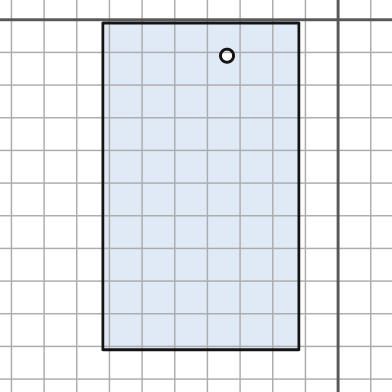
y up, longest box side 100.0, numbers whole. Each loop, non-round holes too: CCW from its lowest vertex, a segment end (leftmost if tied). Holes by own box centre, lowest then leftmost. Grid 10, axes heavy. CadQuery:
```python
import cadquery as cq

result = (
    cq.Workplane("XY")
    .moveTo(-72.0, -101.0)
    .lineTo(-12.0, -101.0)
    .lineTo(-12.0, -1.0)
    .lineTo(-72.0, -1.0)
    .close()
    .moveTo(-34.0, -11.0)
    .circle(2.0)
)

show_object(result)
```